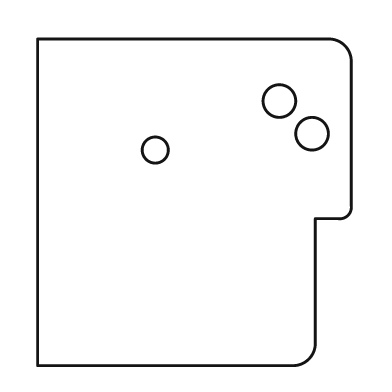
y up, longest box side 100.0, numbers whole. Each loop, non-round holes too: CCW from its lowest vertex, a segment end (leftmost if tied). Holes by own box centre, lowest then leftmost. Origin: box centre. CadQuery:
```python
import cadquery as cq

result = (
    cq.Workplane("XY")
    .moveTo(-48.0, -50.0)
    .lineTo(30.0, -50.0)
    .threePointArc((35.0, -48.0), (37.0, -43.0))
    .lineTo(37.0, -5.0)
    .lineTo(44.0, -5.0)
    .threePointArc((47.0, -4.0), (48.0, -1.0))
    .lineTo(48.0, 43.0)
    .threePointArc((46.0, 48.0), (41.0, 50.0))
    .lineTo(-48.0, 50.0)
    .close()
    .moveTo(-12.0, 16.0)
    .circle(4.0)
    .moveTo(36.0, 21.0)
    .circle(5.0)
    .moveTo(26.0, 31.0)
    .circle(5.0)
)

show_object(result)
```